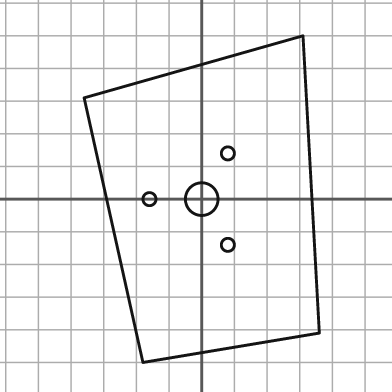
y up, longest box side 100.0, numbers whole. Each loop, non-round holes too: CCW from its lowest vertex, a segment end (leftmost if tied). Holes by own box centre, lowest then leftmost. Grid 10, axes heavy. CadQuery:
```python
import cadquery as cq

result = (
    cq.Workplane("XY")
    .moveTo(-18.0, -50.0)
    .lineTo(36.0, -41.0)
    .lineTo(31.0, 50.0)
    .lineTo(-36.0, 31.0)
    .close()
    .moveTo(8.0, -14.0)
    .circle(2.0)
    .moveTo(-16.0, 0.0)
    .circle(2.0)
    .moveTo(0.0, 0.0)
    .circle(5.0)
    .moveTo(8.0, 14.0)
    .circle(2.0)
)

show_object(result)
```